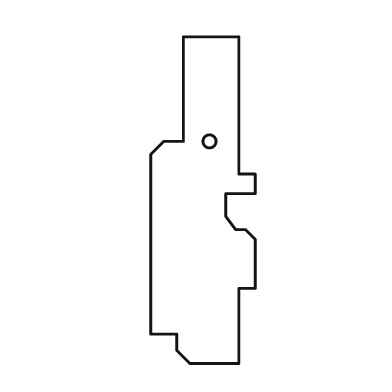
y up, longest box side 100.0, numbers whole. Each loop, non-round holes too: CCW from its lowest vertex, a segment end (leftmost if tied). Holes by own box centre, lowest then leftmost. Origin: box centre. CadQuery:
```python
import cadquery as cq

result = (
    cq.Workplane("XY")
    .moveTo(-4.0, -50.0)
    .lineTo(11.0, -50.0)
    .lineTo(11.0, -27.0)
    .lineTo(16.0, -27.0)
    .lineTo(16.0, -12.0)
    .lineTo(13.0, -9.0)
    .lineTo(10.0, -9.0)
    .lineTo(7.0, -5.0)
    .lineTo(7.0, 2.0)
    .lineTo(16.0, 2.0)
    .lineTo(16.0, 8.0)
    .lineTo(11.0, 8.0)
    .lineTo(11.0, 50.0)
    .lineTo(-6.0, 50.0)
    .lineTo(-6.0, 18.0)
    .lineTo(-12.0, 18.0)
    .lineTo(-16.0, 14.0)
    .lineTo(-16.0, -41.0)
    .lineTo(-8.0, -41.0)
    .lineTo(-8.0, -46.0)
    .close()
    .moveTo(2.0, 18.0)
    .circle(2.0)
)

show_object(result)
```